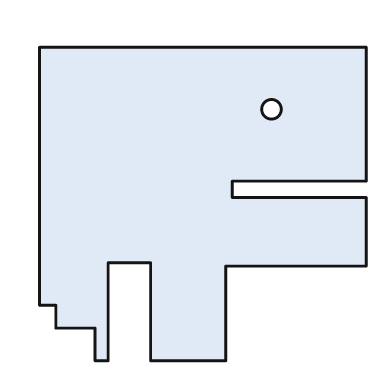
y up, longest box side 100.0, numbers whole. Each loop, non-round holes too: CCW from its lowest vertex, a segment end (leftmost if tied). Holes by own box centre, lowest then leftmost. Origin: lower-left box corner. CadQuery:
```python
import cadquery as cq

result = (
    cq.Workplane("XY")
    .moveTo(17.0, 0.0)
    .lineTo(21.0, 0.0)
    .lineTo(21.0, 30.0)
    .lineTo(34.0, 30.0)
    .lineTo(34.0, 0.0)
    .lineTo(57.0, 0.0)
    .lineTo(57.0, 29.0)
    .lineTo(100.0, 29.0)
    .lineTo(100.0, 50.0)
    .lineTo(59.0, 50.0)
    .lineTo(59.0, 55.0)
    .lineTo(100.0, 55.0)
    .lineTo(100.0, 96.0)
    .lineTo(0.0, 96.0)
    .lineTo(0.0, 17.0)
    .lineTo(5.0, 17.0)
    .lineTo(5.0, 10.0)
    .lineTo(17.0, 10.0)
    .close()
    .moveTo(71.0, 77.0)
    .circle(3.0)
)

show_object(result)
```